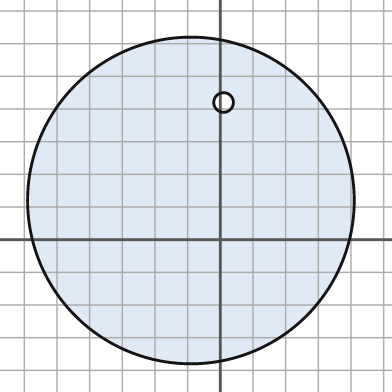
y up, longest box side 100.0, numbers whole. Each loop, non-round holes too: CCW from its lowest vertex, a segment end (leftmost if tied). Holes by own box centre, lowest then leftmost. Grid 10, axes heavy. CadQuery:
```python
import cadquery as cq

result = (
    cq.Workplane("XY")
    .moveTo(-9.0, 12.0)
    .circle(50.0)
    .moveTo(1.0, 42.0)
    .circle(3.0)
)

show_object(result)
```